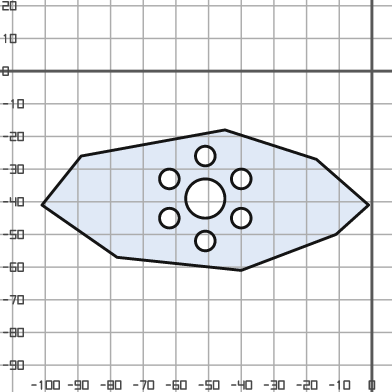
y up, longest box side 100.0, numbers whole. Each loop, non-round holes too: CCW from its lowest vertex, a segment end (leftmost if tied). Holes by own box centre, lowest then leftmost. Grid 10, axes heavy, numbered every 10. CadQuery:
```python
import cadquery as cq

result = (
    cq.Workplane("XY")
    .moveTo(-40.0, -61.0)
    .lineTo(-11.0, -50.0)
    .lineTo(-1.0, -41.0)
    .lineTo(-17.0, -27.0)
    .lineTo(-45.0, -18.0)
    .lineTo(-89.0, -26.0)
    .lineTo(-101.0, -41.0)
    .lineTo(-78.0, -57.0)
    .close()
    .moveTo(-51.0, -52.0)
    .circle(3.0)
    .moveTo(-62.0, -45.0)
    .circle(3.0)
    .moveTo(-40.0, -45.0)
    .circle(3.0)
    .moveTo(-51.0, -39.0)
    .circle(6.0)
    .moveTo(-62.0, -33.0)
    .circle(3.0)
    .moveTo(-40.0, -33.0)
    .circle(3.0)
    .moveTo(-51.0, -26.0)
    .circle(3.0)
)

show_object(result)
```